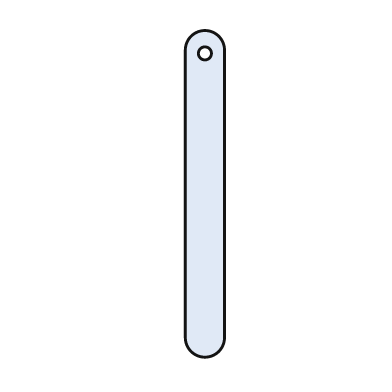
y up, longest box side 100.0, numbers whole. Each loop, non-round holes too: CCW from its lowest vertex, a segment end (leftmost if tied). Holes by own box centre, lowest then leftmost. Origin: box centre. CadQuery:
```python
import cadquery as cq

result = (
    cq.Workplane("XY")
    .moveTo(-6.0, -44.0)
    .threePointArc((0.0, -50.0), (6.0, -44.0))
    .lineTo(6.0, 44.0)
    .threePointArc((0.0, 50.0), (-6.0, 44.0))
    .close()
    .moveTo(0.0, 43.0)
    .circle(2.0)
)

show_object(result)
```